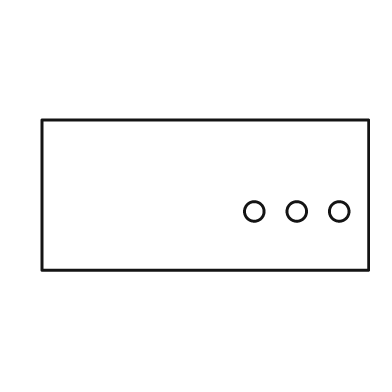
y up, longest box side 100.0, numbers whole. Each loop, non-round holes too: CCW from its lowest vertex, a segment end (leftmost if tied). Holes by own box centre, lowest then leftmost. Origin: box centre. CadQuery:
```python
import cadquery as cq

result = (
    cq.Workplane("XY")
    .moveTo(-50.0, -23.0)
    .lineTo(50.0, -23.0)
    .lineTo(50.0, 23.0)
    .lineTo(-50.0, 23.0)
    .close()
    .moveTo(15.0, -5.0)
    .circle(3.0)
    .moveTo(28.0, -5.0)
    .circle(3.0)
    .moveTo(41.0, -5.0)
    .circle(3.0)
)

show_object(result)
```